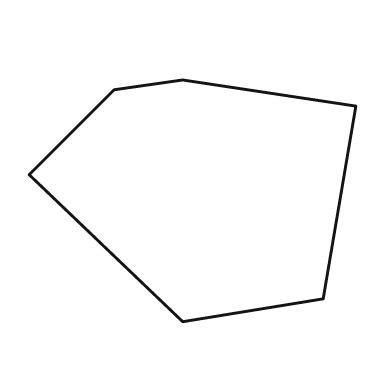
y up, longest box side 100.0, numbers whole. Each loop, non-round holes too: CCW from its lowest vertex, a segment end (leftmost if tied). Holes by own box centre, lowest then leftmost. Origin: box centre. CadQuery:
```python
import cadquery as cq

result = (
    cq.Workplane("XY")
    .moveTo(-3.0, -37.0)
    .lineTo(40.0, -30.0)
    .lineTo(50.0, 29.0)
    .lineTo(-3.0, 37.0)
    .lineTo(-24.0, 34.0)
    .lineTo(-50.0, 8.0)
    .close()
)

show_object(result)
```